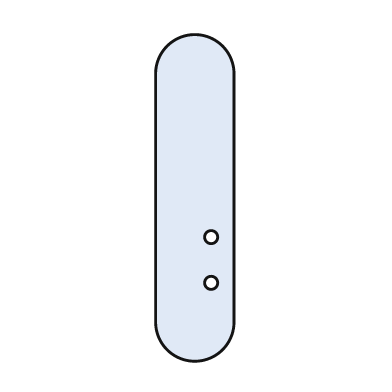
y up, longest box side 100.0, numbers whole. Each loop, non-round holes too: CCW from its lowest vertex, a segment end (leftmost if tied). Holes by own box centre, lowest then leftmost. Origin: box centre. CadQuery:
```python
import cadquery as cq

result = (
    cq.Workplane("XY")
    .moveTo(-12.0, -38.0)
    .threePointArc((0.0, -50.0), (12.0, -38.0))
    .lineTo(12.0, 38.0)
    .threePointArc((0.0, 50.0), (-12.0, 38.0))
    .close()
    .moveTo(5.0, -26.0)
    .circle(2.0)
    .moveTo(5.0, -12.0)
    .circle(2.0)
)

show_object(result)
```